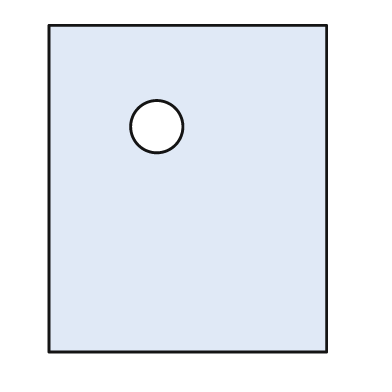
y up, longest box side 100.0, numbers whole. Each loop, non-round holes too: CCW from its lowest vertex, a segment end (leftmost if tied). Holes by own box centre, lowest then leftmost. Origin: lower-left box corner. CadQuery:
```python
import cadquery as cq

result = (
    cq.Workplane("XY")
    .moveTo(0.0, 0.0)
    .lineTo(85.0, 0.0)
    .lineTo(85.0, 100.0)
    .lineTo(0.0, 100.0)
    .close()
    .moveTo(33.0, 69.0)
    .circle(8.0)
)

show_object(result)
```